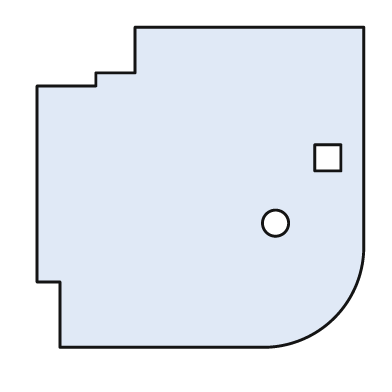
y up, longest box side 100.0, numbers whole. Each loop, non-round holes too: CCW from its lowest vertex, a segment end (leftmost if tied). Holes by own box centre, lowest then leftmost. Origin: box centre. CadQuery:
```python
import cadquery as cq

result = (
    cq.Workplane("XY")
    .moveTo(-43.0, -49.0)
    .lineTo(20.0, -49.0)
    .threePointArc((41.0, -40.0), (50.0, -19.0))
    .lineTo(50.0, 49.0)
    .lineTo(-20.0, 49.0)
    .lineTo(-20.0, 35.0)
    .lineTo(-32.0, 35.0)
    .lineTo(-32.0, 31.0)
    .lineTo(-50.0, 31.0)
    .lineTo(-50.0, -29.0)
    .lineTo(-43.0, -29.0)
    .close()
    .moveTo(23.0, -11.0)
    .circle(4.0)
    .moveTo(35.0, 5.0)
    .lineTo(43.0, 5.0)
    .lineTo(43.0, 13.0)
    .lineTo(35.0, 13.0)
    .close()
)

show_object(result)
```